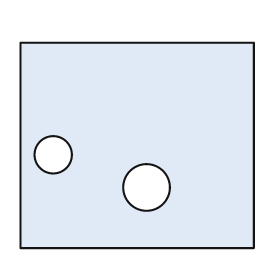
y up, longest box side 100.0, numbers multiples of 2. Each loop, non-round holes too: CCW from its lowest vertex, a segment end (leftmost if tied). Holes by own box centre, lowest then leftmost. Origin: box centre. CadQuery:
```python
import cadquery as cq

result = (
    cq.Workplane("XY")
    .moveTo(-50.0, -44.0)
    .lineTo(50.0, -44.0)
    .lineTo(50.0, 44.0)
    .lineTo(-50.0, 44.0)
    .close()
    .moveTo(4.0, -18.0)
    .circle(10.0)
    .moveTo(-36.0, -4.0)
    .circle(8.0)
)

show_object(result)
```